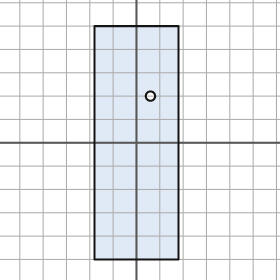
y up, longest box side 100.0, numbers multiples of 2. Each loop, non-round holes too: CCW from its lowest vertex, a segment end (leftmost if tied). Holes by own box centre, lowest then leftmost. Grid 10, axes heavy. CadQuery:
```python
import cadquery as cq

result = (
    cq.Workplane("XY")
    .moveTo(-18.0, -50.0)
    .lineTo(18.0, -50.0)
    .lineTo(18.0, 50.0)
    .lineTo(-18.0, 50.0)
    .close()
    .moveTo(6.0, 20.0)
    .circle(2.0)
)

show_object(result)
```